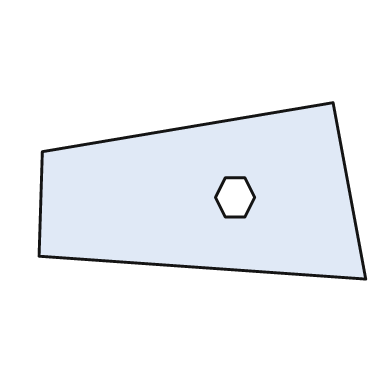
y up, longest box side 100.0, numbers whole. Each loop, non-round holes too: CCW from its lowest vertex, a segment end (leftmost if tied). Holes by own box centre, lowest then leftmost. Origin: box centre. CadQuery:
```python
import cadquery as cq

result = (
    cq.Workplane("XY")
    .moveTo(50.0, -27.0)
    .lineTo(40.0, 27.0)
    .lineTo(-49.0, 12.0)
    .lineTo(-50.0, -20.0)
    .close()
    .moveTo(7.0, -8.0)
    .lineTo(13.0, -8.0)
    .lineTo(16.0, -2.0)
    .lineTo(13.0, 4.0)
    .lineTo(7.0, 4.0)
    .lineTo(4.0, -2.0)
    .close()
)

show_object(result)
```